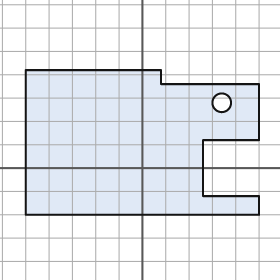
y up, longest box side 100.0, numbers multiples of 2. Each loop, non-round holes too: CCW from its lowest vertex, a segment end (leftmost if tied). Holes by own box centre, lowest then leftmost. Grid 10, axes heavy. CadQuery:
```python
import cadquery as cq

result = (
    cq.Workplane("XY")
    .moveTo(-50.0, -20.0)
    .lineTo(50.0, -20.0)
    .lineTo(50.0, -12.0)
    .lineTo(26.0, -12.0)
    .lineTo(26.0, 12.0)
    .lineTo(50.0, 12.0)
    .lineTo(50.0, 36.0)
    .lineTo(8.0, 36.0)
    .lineTo(8.0, 42.0)
    .lineTo(-50.0, 42.0)
    .close()
    .moveTo(34.0, 28.0)
    .circle(4.0)
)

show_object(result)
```